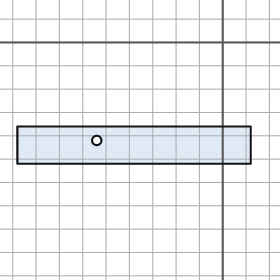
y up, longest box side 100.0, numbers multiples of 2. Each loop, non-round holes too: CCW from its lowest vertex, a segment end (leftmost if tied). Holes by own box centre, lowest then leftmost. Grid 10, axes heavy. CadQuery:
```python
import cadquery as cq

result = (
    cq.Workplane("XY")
    .moveTo(-88.0, -52.0)
    .lineTo(12.0, -52.0)
    .lineTo(12.0, -36.0)
    .lineTo(-88.0, -36.0)
    .close()
    .moveTo(-54.0, -42.0)
    .circle(2.0)
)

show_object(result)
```